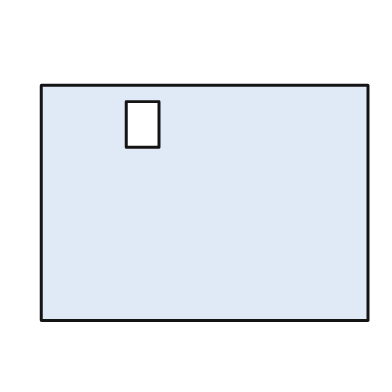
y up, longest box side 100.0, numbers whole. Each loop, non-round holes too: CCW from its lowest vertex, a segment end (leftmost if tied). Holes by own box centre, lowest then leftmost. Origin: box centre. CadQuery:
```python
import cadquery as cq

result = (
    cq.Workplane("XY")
    .moveTo(-50.0, -36.0)
    .lineTo(50.0, -36.0)
    .lineTo(50.0, 36.0)
    .lineTo(-50.0, 36.0)
    .close()
    .moveTo(-24.0, 17.0)
    .lineTo(-14.0, 17.0)
    .lineTo(-14.0, 31.0)
    .lineTo(-24.0, 31.0)
    .close()
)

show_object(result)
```